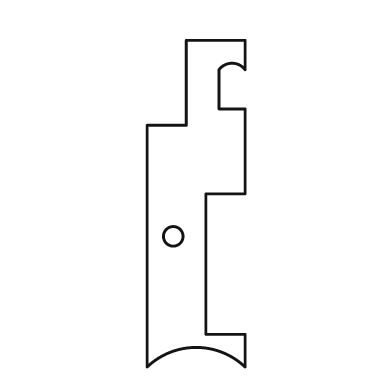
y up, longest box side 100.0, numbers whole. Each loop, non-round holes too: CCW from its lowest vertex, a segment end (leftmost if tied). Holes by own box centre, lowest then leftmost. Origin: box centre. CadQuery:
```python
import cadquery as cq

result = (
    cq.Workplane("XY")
    .moveTo(-15.0, -50.0)
    .threePointArc((0.0, -44.0), (15.0, -50.0))
    .lineTo(15.0, -40.0)
    .lineTo(3.0, -40.0)
    .lineTo(3.0, 3.0)
    .lineTo(15.0, 3.0)
    .lineTo(15.0, 29.0)
    .lineTo(7.0, 29.0)
    .lineTo(7.0, 41.0)
    .threePointArc((11.0, 43.0), (15.0, 41.0))
    .lineTo(15.0, 50.0)
    .lineTo(-3.0, 50.0)
    .lineTo(-3.0, 24.0)
    .lineTo(-15.0, 24.0)
    .close()
    .moveTo(-7.0, -10.0)
    .circle(3.0)
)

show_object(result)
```